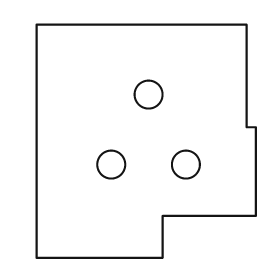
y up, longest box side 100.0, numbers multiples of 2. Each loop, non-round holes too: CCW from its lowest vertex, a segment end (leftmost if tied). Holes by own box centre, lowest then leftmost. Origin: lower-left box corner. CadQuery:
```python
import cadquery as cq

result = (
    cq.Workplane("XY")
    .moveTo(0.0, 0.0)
    .lineTo(54.0, 0.0)
    .lineTo(54.0, 18.0)
    .lineTo(94.0, 18.0)
    .lineTo(94.0, 56.0)
    .lineTo(90.0, 56.0)
    .lineTo(90.0, 100.0)
    .lineTo(0.0, 100.0)
    .close()
    .moveTo(32.0, 40.0)
    .circle(6.0)
    .moveTo(64.0, 40.0)
    .circle(6.0)
    .moveTo(48.0, 70.0)
    .circle(6.0)
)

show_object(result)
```